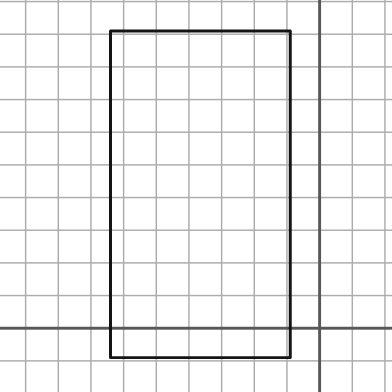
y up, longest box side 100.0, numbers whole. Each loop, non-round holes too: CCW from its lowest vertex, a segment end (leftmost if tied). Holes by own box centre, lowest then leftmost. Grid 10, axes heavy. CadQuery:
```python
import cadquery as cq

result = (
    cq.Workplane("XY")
    .moveTo(-64.0, -9.0)
    .lineTo(-9.0, -9.0)
    .lineTo(-9.0, 91.0)
    .lineTo(-64.0, 91.0)
    .close()
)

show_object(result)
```